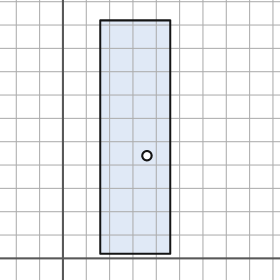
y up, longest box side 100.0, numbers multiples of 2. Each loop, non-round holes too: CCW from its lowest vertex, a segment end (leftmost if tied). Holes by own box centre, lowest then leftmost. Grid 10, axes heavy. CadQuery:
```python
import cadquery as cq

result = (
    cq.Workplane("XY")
    .moveTo(16.0, 2.0)
    .lineTo(46.0, 2.0)
    .lineTo(46.0, 102.0)
    .lineTo(16.0, 102.0)
    .close()
    .moveTo(36.0, 44.0)
    .circle(2.0)
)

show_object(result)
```